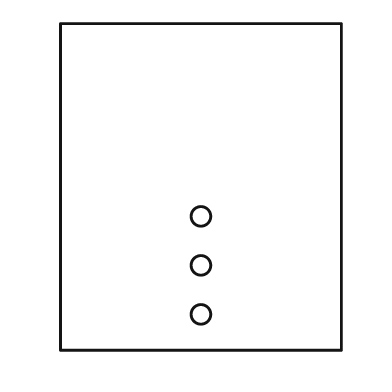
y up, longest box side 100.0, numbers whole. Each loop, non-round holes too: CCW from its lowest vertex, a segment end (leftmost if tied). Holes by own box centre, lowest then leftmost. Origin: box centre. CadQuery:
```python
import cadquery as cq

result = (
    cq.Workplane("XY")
    .moveTo(-43.0, -50.0)
    .lineTo(43.0, -50.0)
    .lineTo(43.0, 50.0)
    .lineTo(-43.0, 50.0)
    .close()
    .moveTo(0.0, -39.0)
    .circle(3.0)
    .moveTo(0.0, -24.0)
    .circle(3.0)
    .moveTo(0.0, -9.0)
    .circle(3.0)
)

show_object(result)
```